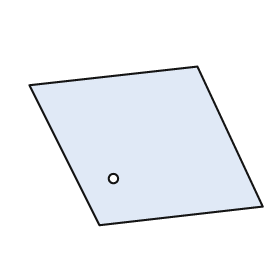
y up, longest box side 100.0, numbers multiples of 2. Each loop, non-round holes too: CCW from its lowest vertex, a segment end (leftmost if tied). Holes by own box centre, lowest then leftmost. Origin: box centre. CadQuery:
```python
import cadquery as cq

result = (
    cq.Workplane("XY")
    .moveTo(-20.0, -34.0)
    .lineTo(50.0, -26.0)
    .lineTo(22.0, 34.0)
    .lineTo(-50.0, 26.0)
    .close()
    .moveTo(-14.0, -14.0)
    .circle(2.0)
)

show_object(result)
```